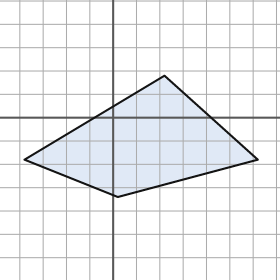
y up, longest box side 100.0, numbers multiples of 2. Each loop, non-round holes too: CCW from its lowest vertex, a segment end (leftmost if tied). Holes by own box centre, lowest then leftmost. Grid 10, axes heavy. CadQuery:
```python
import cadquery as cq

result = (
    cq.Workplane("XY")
    .moveTo(2.0, -34.0)
    .lineTo(62.0, -18.0)
    .lineTo(22.0, 18.0)
    .lineTo(-38.0, -18.0)
    .close()
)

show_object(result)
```